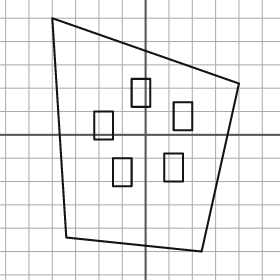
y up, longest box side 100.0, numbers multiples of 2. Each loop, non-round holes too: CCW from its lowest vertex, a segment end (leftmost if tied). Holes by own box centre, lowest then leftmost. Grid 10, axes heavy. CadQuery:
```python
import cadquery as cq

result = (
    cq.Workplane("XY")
    .moveTo(24.0, -50.0)
    .lineTo(40.0, 22.0)
    .lineTo(-40.0, 50.0)
    .lineTo(-34.0, -44.0)
    .close()
    .moveTo(-14.0, -22.0)
    .lineTo(-6.0, -22.0)
    .lineTo(-6.0, -10.0)
    .lineTo(-14.0, -10.0)
    .close()
    .moveTo(8.0, -20.0)
    .lineTo(16.0, -20.0)
    .lineTo(16.0, -8.0)
    .lineTo(8.0, -8.0)
    .close()
    .moveTo(-22.0, -2.0)
    .lineTo(-14.0, -2.0)
    .lineTo(-14.0, 10.0)
    .lineTo(-22.0, 10.0)
    .close()
    .moveTo(12.0, 2.0)
    .lineTo(20.0, 2.0)
    .lineTo(20.0, 14.0)
    .lineTo(12.0, 14.0)
    .close()
    .moveTo(-6.0, 12.0)
    .lineTo(2.0, 12.0)
    .lineTo(2.0, 24.0)
    .lineTo(-6.0, 24.0)
    .close()
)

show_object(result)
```